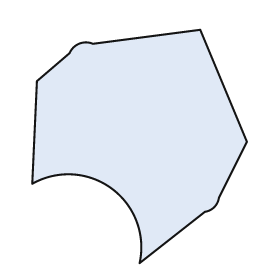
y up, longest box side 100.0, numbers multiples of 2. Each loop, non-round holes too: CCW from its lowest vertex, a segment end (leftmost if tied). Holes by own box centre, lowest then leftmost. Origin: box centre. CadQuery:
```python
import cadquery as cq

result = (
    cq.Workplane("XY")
    .moveTo(0.0, -50.0)
    .lineTo(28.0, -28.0)
    .threePointArc((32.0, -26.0), (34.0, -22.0))
    .lineTo(46.0, 2.0)
    .lineTo(26.0, 50.0)
    .lineTo(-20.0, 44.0)
    .threePointArc((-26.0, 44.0), (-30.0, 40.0))
    .lineTo(-44.0, 28.0)
    .lineTo(-46.0, -16.0)
    .threePointArc((-12.0, -18.0), (0.0, -50.0))
    .close()
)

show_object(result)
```